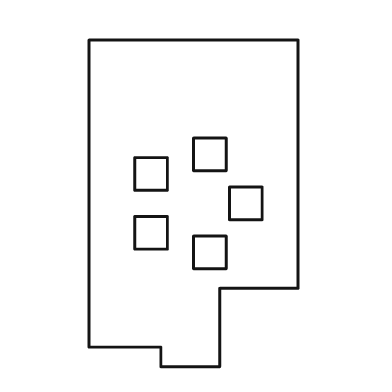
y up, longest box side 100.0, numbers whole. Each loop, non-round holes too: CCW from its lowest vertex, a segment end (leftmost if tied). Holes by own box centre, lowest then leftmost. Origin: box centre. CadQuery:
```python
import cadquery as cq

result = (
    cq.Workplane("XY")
    .moveTo(-10.0, -50.0)
    .lineTo(8.0, -50.0)
    .lineTo(8.0, -26.0)
    .lineTo(32.0, -26.0)
    .lineTo(32.0, 50.0)
    .lineTo(-32.0, 50.0)
    .lineTo(-32.0, -44.0)
    .lineTo(-10.0, -44.0)
    .close()
    .moveTo(0.0, -20.0)
    .lineTo(10.0, -20.0)
    .lineTo(10.0, -10.0)
    .lineTo(0.0, -10.0)
    .close()
    .moveTo(-18.0, -14.0)
    .lineTo(-8.0, -14.0)
    .lineTo(-8.0, -4.0)
    .lineTo(-18.0, -4.0)
    .close()
    .moveTo(11.0, -5.0)
    .lineTo(21.0, -5.0)
    .lineTo(21.0, 5.0)
    .lineTo(11.0, 5.0)
    .close()
    .moveTo(-18.0, 4.0)
    .lineTo(-8.0, 4.0)
    .lineTo(-8.0, 14.0)
    .lineTo(-18.0, 14.0)
    .close()
    .moveTo(0.0, 10.0)
    .lineTo(10.0, 10.0)
    .lineTo(10.0, 20.0)
    .lineTo(0.0, 20.0)
    .close()
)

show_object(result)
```